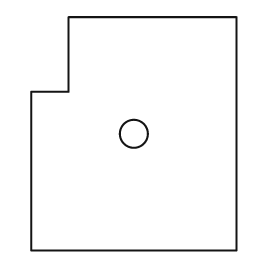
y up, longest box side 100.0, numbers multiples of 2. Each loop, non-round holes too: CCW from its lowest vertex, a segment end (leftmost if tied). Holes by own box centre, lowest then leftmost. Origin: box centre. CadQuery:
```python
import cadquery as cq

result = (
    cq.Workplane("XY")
    .moveTo(-44.0, -50.0)
    .lineTo(44.0, -50.0)
    .lineTo(44.0, 50.0)
    .lineTo(-28.0, 50.0)
    .lineTo(-28.0, 18.0)
    .lineTo(-44.0, 18.0)
    .close()
    .moveTo(0.0, 0.0)
    .circle(6.0)
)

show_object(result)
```